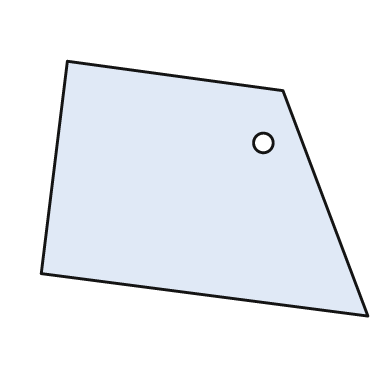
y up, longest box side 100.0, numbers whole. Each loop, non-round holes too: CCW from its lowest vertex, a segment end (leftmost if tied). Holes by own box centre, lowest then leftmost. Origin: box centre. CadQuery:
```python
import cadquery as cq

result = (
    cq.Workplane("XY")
    .moveTo(50.0, -39.0)
    .lineTo(24.0, 30.0)
    .lineTo(-42.0, 39.0)
    .lineTo(-50.0, -26.0)
    .close()
    .moveTo(18.0, 14.0)
    .circle(3.0)
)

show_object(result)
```